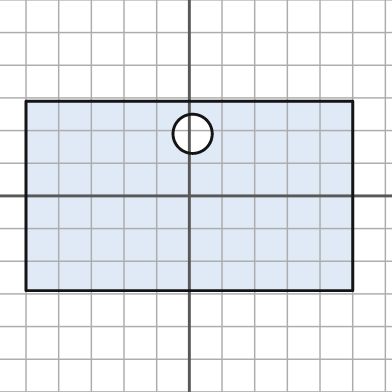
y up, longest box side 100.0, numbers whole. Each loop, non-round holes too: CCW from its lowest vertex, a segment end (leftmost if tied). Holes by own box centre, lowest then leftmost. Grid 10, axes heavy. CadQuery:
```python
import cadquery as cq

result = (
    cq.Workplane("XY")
    .moveTo(-50.0, -29.0)
    .lineTo(50.0, -29.0)
    .lineTo(50.0, 29.0)
    .lineTo(-50.0, 29.0)
    .close()
    .moveTo(1.0, 19.0)
    .circle(6.0)
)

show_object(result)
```